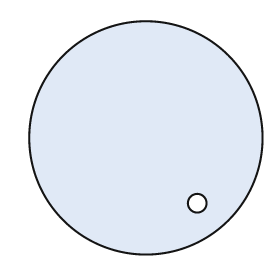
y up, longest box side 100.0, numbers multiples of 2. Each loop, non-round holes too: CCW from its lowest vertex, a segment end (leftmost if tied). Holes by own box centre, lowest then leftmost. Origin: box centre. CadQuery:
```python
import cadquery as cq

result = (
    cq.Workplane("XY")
    .moveTo(0.0, 0.0)
    .circle(50.0)
    .moveTo(22.0, -28.0)
    .circle(4.0)
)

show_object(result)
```